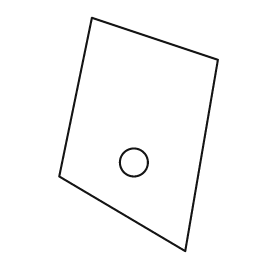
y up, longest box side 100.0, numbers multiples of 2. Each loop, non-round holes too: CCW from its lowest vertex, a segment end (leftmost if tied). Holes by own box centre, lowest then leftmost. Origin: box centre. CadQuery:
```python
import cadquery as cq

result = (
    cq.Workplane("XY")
    .moveTo(20.0, -50.0)
    .lineTo(34.0, 32.0)
    .lineTo(-20.0, 50.0)
    .lineTo(-34.0, -18.0)
    .close()
    .moveTo(-2.0, -12.0)
    .circle(6.0)
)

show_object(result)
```